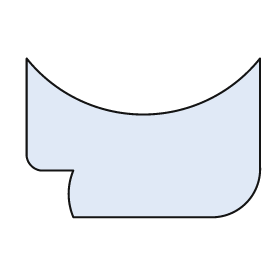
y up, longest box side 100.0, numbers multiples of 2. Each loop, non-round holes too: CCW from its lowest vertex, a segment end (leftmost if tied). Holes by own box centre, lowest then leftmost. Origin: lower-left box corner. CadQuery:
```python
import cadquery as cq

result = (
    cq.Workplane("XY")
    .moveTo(20.0, 0.0)
    .lineTo(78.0, 0.0)
    .threePointArc((94.0, 6.0), (100.0, 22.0))
    .lineTo(100.0, 68.0)
    .threePointArc((50.0, 44.0), (0.0, 68.0))
    .lineTo(0.0, 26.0)
    .threePointArc((2.0, 22.0), (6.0, 20.0))
    .lineTo(20.0, 20.0)
    .threePointArc((18.0, 10.0), (20.0, 0.0))
    .close()
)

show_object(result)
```